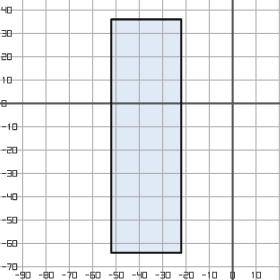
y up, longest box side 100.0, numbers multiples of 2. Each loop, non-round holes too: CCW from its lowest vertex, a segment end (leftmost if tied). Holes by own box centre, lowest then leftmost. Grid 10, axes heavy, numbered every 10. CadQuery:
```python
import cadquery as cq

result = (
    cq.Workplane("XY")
    .moveTo(-52.0, -64.0)
    .lineTo(-22.0, -64.0)
    .lineTo(-22.0, 36.0)
    .lineTo(-52.0, 36.0)
    .close()
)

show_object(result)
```